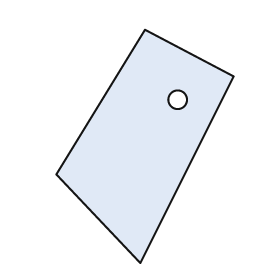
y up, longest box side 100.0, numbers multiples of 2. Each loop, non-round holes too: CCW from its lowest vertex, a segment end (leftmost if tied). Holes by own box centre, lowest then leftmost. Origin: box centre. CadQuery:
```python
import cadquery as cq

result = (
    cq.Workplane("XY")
    .moveTo(-2.0, -50.0)
    .lineTo(38.0, 30.0)
    .lineTo(0.0, 50.0)
    .lineTo(-38.0, -12.0)
    .close()
    .moveTo(14.0, 20.0)
    .circle(4.0)
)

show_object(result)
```